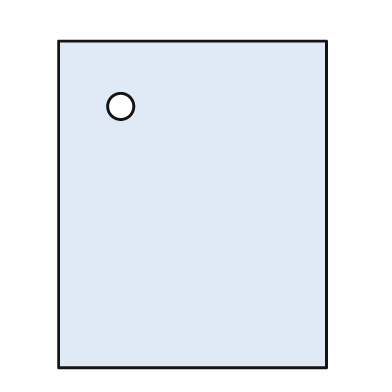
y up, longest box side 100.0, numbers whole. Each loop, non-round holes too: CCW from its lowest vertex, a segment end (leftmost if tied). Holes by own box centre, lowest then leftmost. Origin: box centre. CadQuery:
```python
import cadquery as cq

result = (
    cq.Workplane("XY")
    .moveTo(-41.0, -50.0)
    .lineTo(41.0, -50.0)
    .lineTo(41.0, 50.0)
    .lineTo(-41.0, 50.0)
    .close()
    .moveTo(-22.0, 30.0)
    .circle(4.0)
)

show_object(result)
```